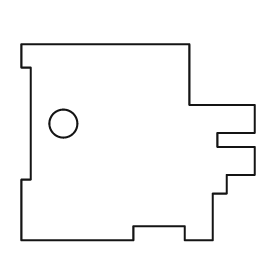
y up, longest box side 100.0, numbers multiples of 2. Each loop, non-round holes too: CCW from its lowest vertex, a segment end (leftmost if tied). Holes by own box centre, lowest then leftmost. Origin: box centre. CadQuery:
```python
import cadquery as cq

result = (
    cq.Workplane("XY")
    .moveTo(-50.0, -42.0)
    .lineTo(-2.0, -42.0)
    .lineTo(-2.0, -36.0)
    .lineTo(20.0, -36.0)
    .lineTo(20.0, -42.0)
    .lineTo(32.0, -42.0)
    .lineTo(32.0, -22.0)
    .lineTo(38.0, -22.0)
    .lineTo(38.0, -14.0)
    .lineTo(50.0, -14.0)
    .lineTo(50.0, -2.0)
    .lineTo(34.0, -2.0)
    .lineTo(34.0, 4.0)
    .lineTo(50.0, 4.0)
    .lineTo(50.0, 16.0)
    .lineTo(22.0, 16.0)
    .lineTo(22.0, 42.0)
    .lineTo(-50.0, 42.0)
    .lineTo(-50.0, 32.0)
    .lineTo(-46.0, 32.0)
    .lineTo(-46.0, -16.0)
    .lineTo(-50.0, -16.0)
    .close()
    .moveTo(-32.0, 8.0)
    .circle(6.0)
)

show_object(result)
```